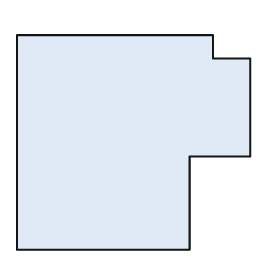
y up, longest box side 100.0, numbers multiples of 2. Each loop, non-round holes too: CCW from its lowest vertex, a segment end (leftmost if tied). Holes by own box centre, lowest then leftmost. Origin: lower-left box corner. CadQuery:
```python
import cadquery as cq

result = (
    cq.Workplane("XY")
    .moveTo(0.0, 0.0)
    .lineTo(74.0, 0.0)
    .lineTo(74.0, 40.0)
    .lineTo(100.0, 40.0)
    .lineTo(100.0, 82.0)
    .lineTo(84.0, 82.0)
    .lineTo(84.0, 92.0)
    .lineTo(0.0, 92.0)
    .close()
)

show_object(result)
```